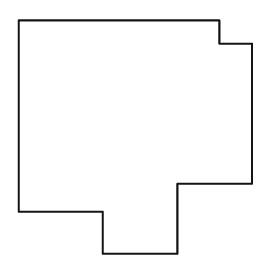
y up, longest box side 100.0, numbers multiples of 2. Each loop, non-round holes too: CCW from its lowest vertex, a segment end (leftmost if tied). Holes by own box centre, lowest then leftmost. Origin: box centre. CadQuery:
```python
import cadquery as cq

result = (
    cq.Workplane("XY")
    .moveTo(-14.0, -50.0)
    .lineTo(18.0, -50.0)
    .lineTo(18.0, -20.0)
    .lineTo(50.0, -20.0)
    .lineTo(50.0, 40.0)
    .lineTo(36.0, 40.0)
    .lineTo(36.0, 50.0)
    .lineTo(-50.0, 50.0)
    .lineTo(-50.0, -32.0)
    .lineTo(-14.0, -32.0)
    .close()
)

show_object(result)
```